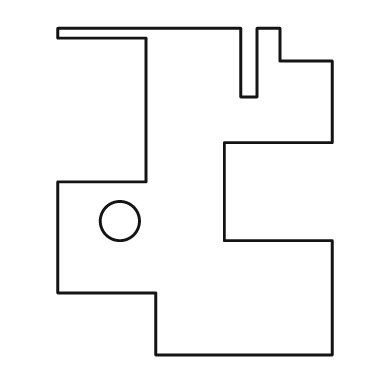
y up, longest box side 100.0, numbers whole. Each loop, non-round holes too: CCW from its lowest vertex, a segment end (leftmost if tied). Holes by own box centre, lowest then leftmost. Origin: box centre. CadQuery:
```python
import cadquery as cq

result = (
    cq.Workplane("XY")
    .moveTo(-12.0, -50.0)
    .lineTo(42.0, -50.0)
    .lineTo(42.0, -15.0)
    .lineTo(9.0, -15.0)
    .lineTo(9.0, 15.0)
    .lineTo(42.0, 15.0)
    .lineTo(42.0, 40.0)
    .lineTo(26.0, 40.0)
    .lineTo(26.0, 50.0)
    .lineTo(19.0, 50.0)
    .lineTo(19.0, 29.0)
    .lineTo(14.0, 29.0)
    .lineTo(14.0, 50.0)
    .lineTo(-42.0, 50.0)
    .lineTo(-42.0, 47.0)
    .lineTo(-15.0, 47.0)
    .lineTo(-15.0, 3.0)
    .lineTo(-42.0, 3.0)
    .lineTo(-42.0, -31.0)
    .lineTo(-12.0, -31.0)
    .close()
    .moveTo(-23.0, -9.0)
    .circle(6.0)
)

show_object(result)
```